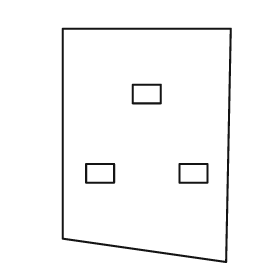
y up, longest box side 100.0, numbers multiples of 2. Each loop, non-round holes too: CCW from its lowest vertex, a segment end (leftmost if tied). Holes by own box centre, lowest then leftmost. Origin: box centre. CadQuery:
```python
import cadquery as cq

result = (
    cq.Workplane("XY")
    .moveTo(34.0, -50.0)
    .lineTo(36.0, 50.0)
    .lineTo(-36.0, 50.0)
    .lineTo(-36.0, -40.0)
    .close()
    .moveTo(-26.0, -16.0)
    .lineTo(-14.0, -16.0)
    .lineTo(-14.0, -8.0)
    .lineTo(-26.0, -8.0)
    .close()
    .moveTo(14.0, -16.0)
    .lineTo(26.0, -16.0)
    .lineTo(26.0, -8.0)
    .lineTo(14.0, -8.0)
    .close()
    .moveTo(-6.0, 18.0)
    .lineTo(6.0, 18.0)
    .lineTo(6.0, 26.0)
    .lineTo(-6.0, 26.0)
    .close()
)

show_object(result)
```